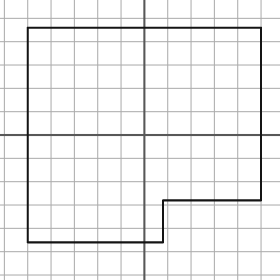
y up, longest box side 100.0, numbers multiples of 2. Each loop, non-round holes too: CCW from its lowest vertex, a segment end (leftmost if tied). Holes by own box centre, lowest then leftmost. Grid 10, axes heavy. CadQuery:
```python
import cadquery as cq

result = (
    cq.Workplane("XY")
    .moveTo(-50.0, -46.0)
    .lineTo(8.0, -46.0)
    .lineTo(8.0, -28.0)
    .lineTo(50.0, -28.0)
    .lineTo(50.0, 46.0)
    .lineTo(-50.0, 46.0)
    .close()
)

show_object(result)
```